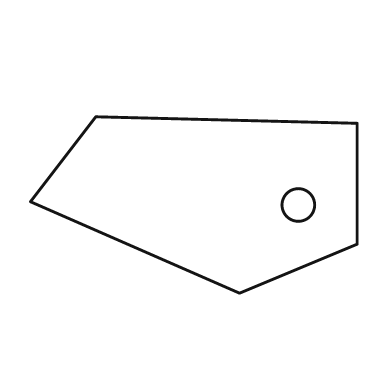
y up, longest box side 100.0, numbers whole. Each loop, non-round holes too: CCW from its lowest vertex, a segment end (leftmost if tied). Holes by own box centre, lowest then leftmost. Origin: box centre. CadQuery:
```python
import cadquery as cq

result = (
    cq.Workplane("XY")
    .moveTo(14.0, -27.0)
    .lineTo(50.0, -12.0)
    .lineTo(50.0, 25.0)
    .lineTo(-30.0, 27.0)
    .lineTo(-50.0, 1.0)
    .close()
    .moveTo(32.0, 0.0)
    .circle(5.0)
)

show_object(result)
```